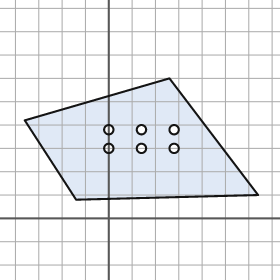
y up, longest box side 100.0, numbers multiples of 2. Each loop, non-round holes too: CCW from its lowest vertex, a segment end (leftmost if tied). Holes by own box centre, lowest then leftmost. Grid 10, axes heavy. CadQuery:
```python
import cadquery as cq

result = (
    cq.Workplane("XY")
    .moveTo(-14.0, 8.0)
    .lineTo(64.0, 10.0)
    .lineTo(26.0, 60.0)
    .lineTo(-36.0, 42.0)
    .close()
    .moveTo(0.0, 30.0)
    .circle(2.0)
    .moveTo(14.0, 30.0)
    .circle(2.0)
    .moveTo(28.0, 30.0)
    .circle(2.0)
    .moveTo(0.0, 38.0)
    .circle(2.0)
    .moveTo(14.0, 38.0)
    .circle(2.0)
    .moveTo(28.0, 38.0)
    .circle(2.0)
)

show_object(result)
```